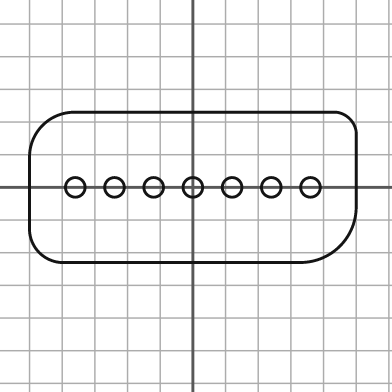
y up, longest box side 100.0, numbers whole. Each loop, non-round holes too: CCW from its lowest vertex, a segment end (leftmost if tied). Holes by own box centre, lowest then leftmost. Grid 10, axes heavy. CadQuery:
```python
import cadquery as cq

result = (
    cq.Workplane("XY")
    .moveTo(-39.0, -23.0)
    .lineTo(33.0, -23.0)
    .threePointArc((45.0, -18.0), (50.0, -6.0))
    .lineTo(50.0, 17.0)
    .threePointArc((48.0, 21.0), (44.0, 23.0))
    .lineTo(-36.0, 23.0)
    .threePointArc((-46.0, 19.0), (-50.0, 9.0))
    .lineTo(-50.0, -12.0)
    .threePointArc((-47.0, -20.0), (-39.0, -23.0))
    .close()
    .moveTo(-36.0, 0.0)
    .circle(3.0)
    .moveTo(-24.0, 0.0)
    .circle(3.0)
    .moveTo(-12.0, 0.0)
    .circle(3.0)
    .moveTo(0.0, 0.0)
    .circle(3.0)
    .moveTo(12.0, 0.0)
    .circle(3.0)
    .moveTo(24.0, 0.0)
    .circle(3.0)
    .moveTo(36.0, 0.0)
    .circle(3.0)
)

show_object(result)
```